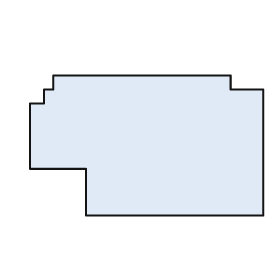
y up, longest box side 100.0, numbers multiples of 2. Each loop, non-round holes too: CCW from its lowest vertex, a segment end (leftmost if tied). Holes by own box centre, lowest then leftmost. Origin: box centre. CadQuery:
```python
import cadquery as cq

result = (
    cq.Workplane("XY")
    .moveTo(-26.0, -30.0)
    .lineTo(50.0, -30.0)
    .lineTo(50.0, 24.0)
    .lineTo(36.0, 24.0)
    .lineTo(36.0, 30.0)
    .lineTo(-40.0, 30.0)
    .lineTo(-40.0, 24.0)
    .lineTo(-44.0, 24.0)
    .lineTo(-44.0, 18.0)
    .lineTo(-50.0, 18.0)
    .lineTo(-50.0, -10.0)
    .lineTo(-26.0, -10.0)
    .close()
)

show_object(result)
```